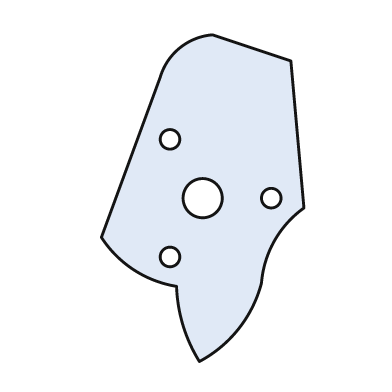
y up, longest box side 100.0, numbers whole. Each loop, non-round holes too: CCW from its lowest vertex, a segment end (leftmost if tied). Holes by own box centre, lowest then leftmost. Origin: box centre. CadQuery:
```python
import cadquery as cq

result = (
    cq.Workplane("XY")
    .moveTo(-1.0, -50.0)
    .threePointArc((11.0, -40.0), (18.0, -26.0))
    .threePointArc((22.0, -13.0), (31.0, -3.0))
    .lineTo(27.0, 42.0)
    .lineTo(3.0, 50.0)
    .threePointArc((-7.0, 46.0), (-13.0, 37.0))
    .lineTo(-31.0, -12.0)
    .threePointArc((-21.0, -22.0), (-8.0, -27.0))
    .threePointArc((-6.0, -39.0), (-1.0, -50.0))
    .close()
    .moveTo(-10.0, -18.0)
    .circle(3.0)
    .moveTo(0.0, 0.0)
    .circle(6.0)
    .moveTo(21.0, 0.0)
    .circle(3.0)
    .moveTo(-10.0, 18.0)
    .circle(3.0)
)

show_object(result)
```